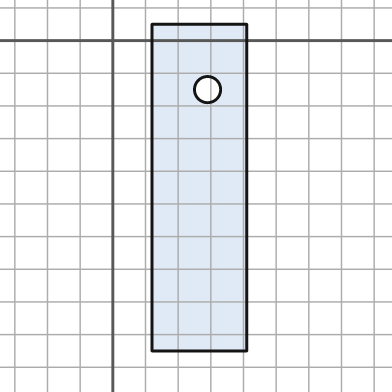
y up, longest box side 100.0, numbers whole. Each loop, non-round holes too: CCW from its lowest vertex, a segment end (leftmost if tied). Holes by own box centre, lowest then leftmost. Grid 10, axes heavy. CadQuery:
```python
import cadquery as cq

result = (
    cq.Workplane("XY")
    .moveTo(12.0, -95.0)
    .lineTo(41.0, -95.0)
    .lineTo(41.0, 5.0)
    .lineTo(12.0, 5.0)
    .close()
    .moveTo(29.0, -15.0)
    .circle(4.0)
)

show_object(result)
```